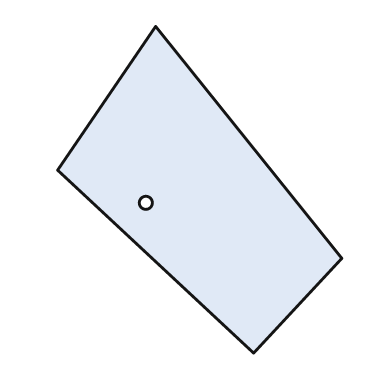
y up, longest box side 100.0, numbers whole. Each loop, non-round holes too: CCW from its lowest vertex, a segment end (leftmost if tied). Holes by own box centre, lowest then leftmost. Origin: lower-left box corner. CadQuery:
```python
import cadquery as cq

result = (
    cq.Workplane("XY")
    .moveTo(60.0, 0.0)
    .lineTo(87.0, 29.0)
    .lineTo(30.0, 100.0)
    .lineTo(0.0, 56.0)
    .close()
    .moveTo(27.0, 46.0)
    .circle(2.0)
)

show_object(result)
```